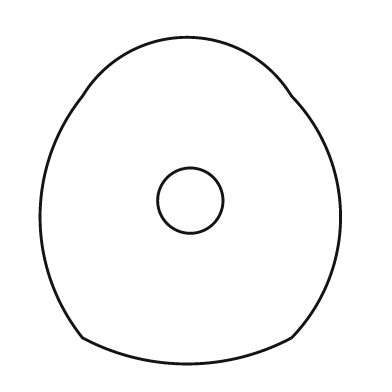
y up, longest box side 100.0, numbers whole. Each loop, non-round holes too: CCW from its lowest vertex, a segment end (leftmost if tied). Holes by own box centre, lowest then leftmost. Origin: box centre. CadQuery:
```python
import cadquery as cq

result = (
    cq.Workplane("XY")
    .moveTo(-33.0, -42.0)
    .threePointArc((-1.0, -50.0), (31.0, -42.0))
    .threePointArc((46.0, -5.0), (31.0, 32.0))
    .threePointArc((-1.0, 50.0), (-33.0, 32.0))
    .threePointArc((-46.0, -5.0), (-33.0, -42.0))
    .close()
    .moveTo(0.0, 0.0)
    .circle(10.0)
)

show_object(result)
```